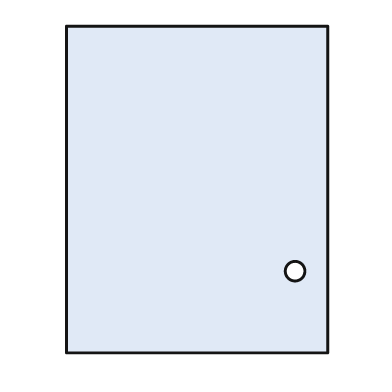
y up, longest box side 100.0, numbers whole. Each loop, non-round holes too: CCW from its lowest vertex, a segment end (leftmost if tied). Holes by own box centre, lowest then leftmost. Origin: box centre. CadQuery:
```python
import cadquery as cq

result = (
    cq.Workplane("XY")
    .moveTo(-40.0, -50.0)
    .lineTo(40.0, -50.0)
    .lineTo(40.0, 50.0)
    .lineTo(-40.0, 50.0)
    .close()
    .moveTo(30.0, -25.0)
    .circle(3.0)
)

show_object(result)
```